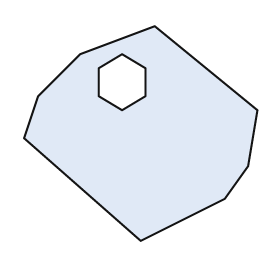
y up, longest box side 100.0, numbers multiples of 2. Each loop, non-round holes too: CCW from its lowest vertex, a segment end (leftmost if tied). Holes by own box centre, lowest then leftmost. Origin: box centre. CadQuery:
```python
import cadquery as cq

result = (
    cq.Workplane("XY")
    .moveTo(0.0, -46.0)
    .lineTo(36.0, -28.0)
    .lineTo(46.0, -14.0)
    .lineTo(50.0, 10.0)
    .lineTo(6.0, 46.0)
    .lineTo(-26.0, 34.0)
    .lineTo(-44.0, 16.0)
    .lineTo(-50.0, -2.0)
    .close()
    .moveTo(-8.0, 10.0)
    .lineTo(2.0, 16.0)
    .lineTo(2.0, 28.0)
    .lineTo(-8.0, 34.0)
    .lineTo(-18.0, 28.0)
    .lineTo(-18.0, 16.0)
    .close()
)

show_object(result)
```